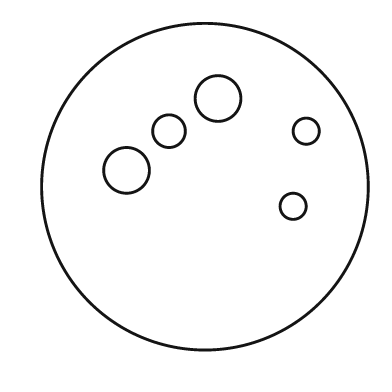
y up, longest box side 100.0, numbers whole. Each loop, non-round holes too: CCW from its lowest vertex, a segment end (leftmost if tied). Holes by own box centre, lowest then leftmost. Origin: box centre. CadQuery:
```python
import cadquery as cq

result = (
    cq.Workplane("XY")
    .moveTo(0.0, 0.0)
    .circle(50.0)
    .moveTo(27.0, -6.0)
    .circle(4.0)
    .moveTo(-24.0, 5.0)
    .circle(7.0)
    .moveTo(-11.0, 17.0)
    .circle(5.0)
    .moveTo(31.0, 17.0)
    .circle(4.0)
    .moveTo(4.0, 27.0)
    .circle(7.0)
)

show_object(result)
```